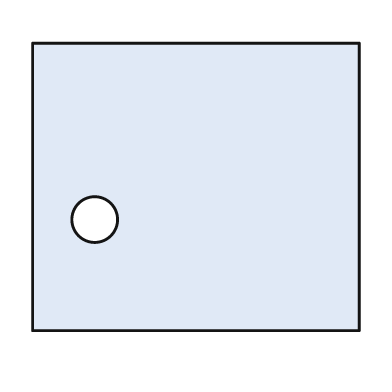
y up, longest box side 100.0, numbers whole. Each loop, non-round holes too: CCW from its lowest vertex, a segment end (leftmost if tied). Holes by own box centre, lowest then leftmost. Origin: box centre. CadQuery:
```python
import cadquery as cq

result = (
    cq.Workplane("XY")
    .moveTo(-50.0, -44.0)
    .lineTo(50.0, -44.0)
    .lineTo(50.0, 44.0)
    .lineTo(-50.0, 44.0)
    .close()
    .moveTo(-31.0, -10.0)
    .circle(7.0)
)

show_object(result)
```